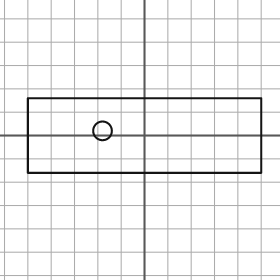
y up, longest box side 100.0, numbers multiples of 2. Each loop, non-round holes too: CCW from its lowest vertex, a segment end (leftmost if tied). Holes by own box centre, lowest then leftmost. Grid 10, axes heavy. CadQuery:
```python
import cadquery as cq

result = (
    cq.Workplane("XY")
    .moveTo(-50.0, -16.0)
    .lineTo(50.0, -16.0)
    .lineTo(50.0, 16.0)
    .lineTo(-50.0, 16.0)
    .close()
    .moveTo(-18.0, 2.0)
    .circle(4.0)
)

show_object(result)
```